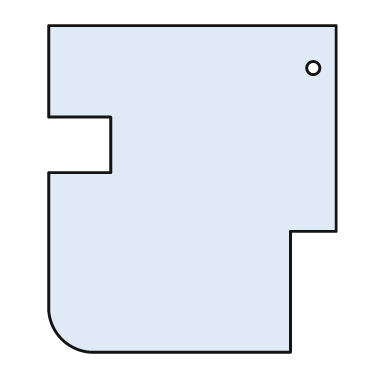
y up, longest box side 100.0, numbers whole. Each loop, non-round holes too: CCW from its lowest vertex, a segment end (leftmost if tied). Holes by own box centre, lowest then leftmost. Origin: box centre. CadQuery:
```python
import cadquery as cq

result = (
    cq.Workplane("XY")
    .moveTo(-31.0, -50.0)
    .lineTo(30.0, -50.0)
    .lineTo(30.0, -13.0)
    .lineTo(44.0, -13.0)
    .lineTo(44.0, 50.0)
    .lineTo(-44.0, 50.0)
    .lineTo(-44.0, 22.0)
    .lineTo(-25.0, 22.0)
    .lineTo(-25.0, 5.0)
    .lineTo(-44.0, 5.0)
    .lineTo(-44.0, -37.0)
    .threePointArc((-40.0, -46.0), (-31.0, -50.0))
    .close()
    .moveTo(37.0, 37.0)
    .circle(2.0)
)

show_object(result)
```